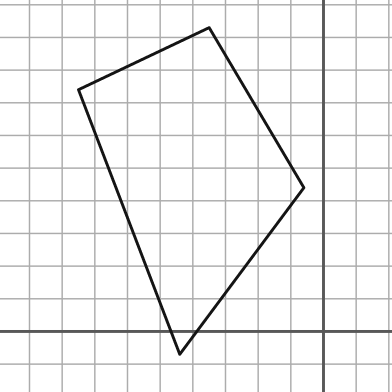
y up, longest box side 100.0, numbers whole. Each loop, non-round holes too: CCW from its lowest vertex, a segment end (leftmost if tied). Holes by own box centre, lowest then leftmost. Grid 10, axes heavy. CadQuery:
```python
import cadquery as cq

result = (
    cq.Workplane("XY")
    .moveTo(-44.0, -7.0)
    .lineTo(-6.0, 44.0)
    .lineTo(-35.0, 93.0)
    .lineTo(-75.0, 74.0)
    .close()
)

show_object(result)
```